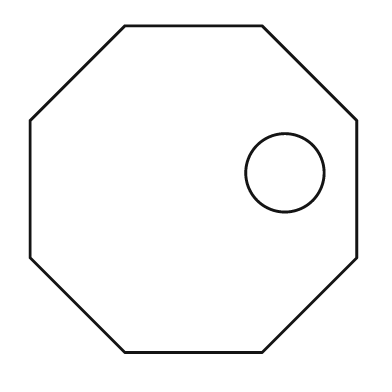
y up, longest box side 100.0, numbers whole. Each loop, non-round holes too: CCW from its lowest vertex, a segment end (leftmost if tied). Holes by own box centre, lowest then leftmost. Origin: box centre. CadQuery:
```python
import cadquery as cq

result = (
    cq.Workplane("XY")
    .moveTo(-21.0, -50.0)
    .lineTo(21.0, -50.0)
    .lineTo(50.0, -21.0)
    .lineTo(50.0, 21.0)
    .lineTo(21.0, 50.0)
    .lineTo(-21.0, 50.0)
    .lineTo(-50.0, 21.0)
    .lineTo(-50.0, -21.0)
    .close()
    .moveTo(28.0, 5.0)
    .circle(12.0)
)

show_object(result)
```